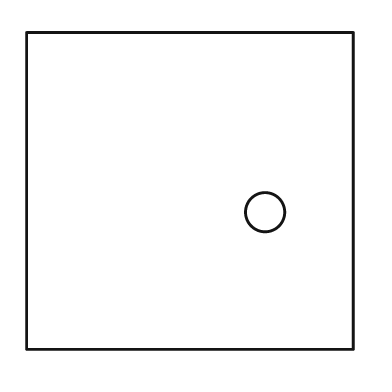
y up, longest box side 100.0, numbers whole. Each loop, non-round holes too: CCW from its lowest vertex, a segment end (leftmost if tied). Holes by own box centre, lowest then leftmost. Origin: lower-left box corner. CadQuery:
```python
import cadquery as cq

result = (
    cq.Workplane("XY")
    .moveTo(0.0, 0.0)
    .lineTo(100.0, 0.0)
    .lineTo(100.0, 97.0)
    .lineTo(0.0, 97.0)
    .close()
    .moveTo(73.0, 42.0)
    .circle(6.0)
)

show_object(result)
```